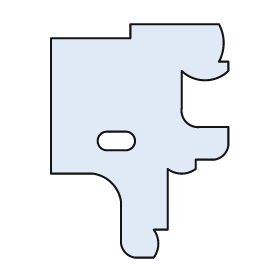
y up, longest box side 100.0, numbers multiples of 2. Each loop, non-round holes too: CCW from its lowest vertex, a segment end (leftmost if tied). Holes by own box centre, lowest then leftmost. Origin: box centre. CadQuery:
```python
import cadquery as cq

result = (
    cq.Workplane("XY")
    .moveTo(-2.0, -50.0)
    .lineTo(6.0, -50.0)
    .threePointArc((8.0, -44.0), (6.0, -38.0))
    .lineTo(12.0, -38.0)
    .lineTo(12.0, -12.0)
    .threePointArc((18.0, -14.0), (24.0, -12.0))
    .lineTo(24.0, -8.0)
    .lineTo(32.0, -8.0)
    .threePointArc((36.0, -6.0), (38.0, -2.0))
    .lineTo(38.0, 6.0)
    .lineTo(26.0, 6.0)
    .threePointArc((20.0, 8.0), (18.0, 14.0))
    .lineTo(18.0, 30.0)
    .threePointArc((28.0, 26.0), (38.0, 30.0))
    .lineTo(38.0, 34.0)
    .lineTo(34.0, 34.0)
    .threePointArc((36.0, 42.0), (34.0, 50.0))
    .lineTo(-4.0, 50.0)
    .lineTo(-4.0, 44.0)
    .lineTo(-38.0, 44.0)
    .lineTo(-38.0, -14.0)
    .lineTo(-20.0, -14.0)
    .threePointArc((-12.0, -18.0), (-8.0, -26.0))
    .lineTo(-8.0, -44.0)
    .threePointArc((-6.0, -48.0), (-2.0, -50.0))
    .close()
    .moveTo(-14.0, -4.0)
    .lineTo(-6.0, -4.0)
    .threePointArc((-2.0, 0.0), (-6.0, 4.0))
    .lineTo(-14.0, 4.0)
    .threePointArc((-18.0, 0.0), (-14.0, -4.0))
    .close()
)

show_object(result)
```